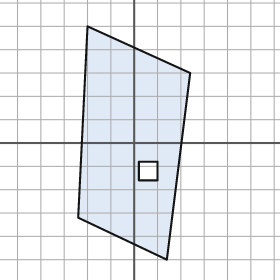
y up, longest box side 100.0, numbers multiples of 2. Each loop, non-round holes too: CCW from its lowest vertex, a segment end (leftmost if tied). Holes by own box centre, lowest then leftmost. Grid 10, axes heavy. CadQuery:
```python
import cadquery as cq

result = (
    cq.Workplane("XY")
    .moveTo(14.0, -50.0)
    .lineTo(24.0, 30.0)
    .lineTo(-20.0, 50.0)
    .lineTo(-24.0, -32.0)
    .close()
    .moveTo(2.0, -16.0)
    .lineTo(10.0, -16.0)
    .lineTo(10.0, -8.0)
    .lineTo(2.0, -8.0)
    .close()
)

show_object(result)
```